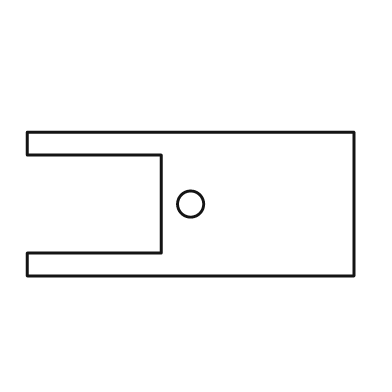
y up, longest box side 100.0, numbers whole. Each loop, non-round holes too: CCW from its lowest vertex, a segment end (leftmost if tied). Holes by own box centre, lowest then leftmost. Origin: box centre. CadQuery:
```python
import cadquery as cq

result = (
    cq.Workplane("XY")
    .moveTo(-50.0, -22.0)
    .lineTo(50.0, -22.0)
    .lineTo(50.0, 22.0)
    .lineTo(-50.0, 22.0)
    .lineTo(-50.0, 15.0)
    .lineTo(-9.0, 15.0)
    .lineTo(-9.0, -15.0)
    .lineTo(-50.0, -15.0)
    .close()
    .moveTo(0.0, 0.0)
    .circle(4.0)
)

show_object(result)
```